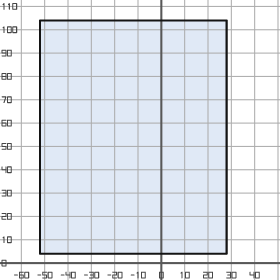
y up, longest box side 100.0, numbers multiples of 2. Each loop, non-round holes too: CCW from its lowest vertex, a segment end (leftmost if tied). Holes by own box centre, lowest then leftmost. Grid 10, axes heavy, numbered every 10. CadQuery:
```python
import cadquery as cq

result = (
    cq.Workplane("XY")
    .moveTo(-52.0, 4.0)
    .lineTo(28.0, 4.0)
    .lineTo(28.0, 104.0)
    .lineTo(-52.0, 104.0)
    .close()
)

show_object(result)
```